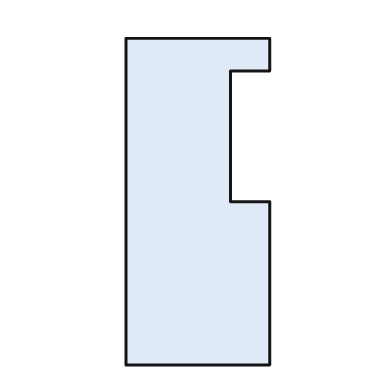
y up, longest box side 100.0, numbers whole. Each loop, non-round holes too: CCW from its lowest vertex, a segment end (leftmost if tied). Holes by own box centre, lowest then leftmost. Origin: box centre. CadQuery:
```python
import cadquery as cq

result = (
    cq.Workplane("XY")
    .moveTo(-22.0, -50.0)
    .lineTo(22.0, -50.0)
    .lineTo(22.0, 0.0)
    .lineTo(10.0, 0.0)
    .lineTo(10.0, 40.0)
    .lineTo(22.0, 40.0)
    .lineTo(22.0, 50.0)
    .lineTo(-22.0, 50.0)
    .close()
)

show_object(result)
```